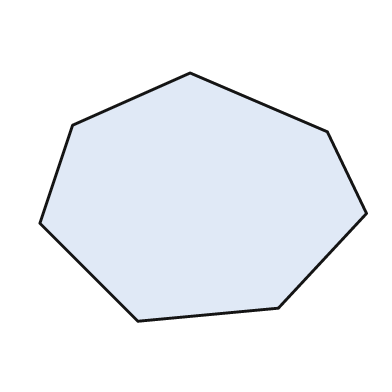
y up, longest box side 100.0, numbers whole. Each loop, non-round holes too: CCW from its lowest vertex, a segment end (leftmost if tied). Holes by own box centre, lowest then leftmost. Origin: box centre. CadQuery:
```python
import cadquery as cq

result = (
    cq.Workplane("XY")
    .moveTo(-20.0, -38.0)
    .lineTo(23.0, -34.0)
    .lineTo(50.0, -5.0)
    .lineTo(38.0, 20.0)
    .lineTo(-4.0, 38.0)
    .lineTo(-40.0, 22.0)
    .lineTo(-50.0, -8.0)
    .close()
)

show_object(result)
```